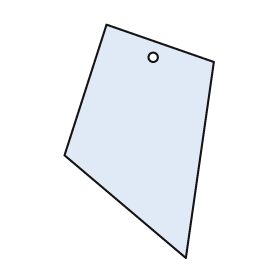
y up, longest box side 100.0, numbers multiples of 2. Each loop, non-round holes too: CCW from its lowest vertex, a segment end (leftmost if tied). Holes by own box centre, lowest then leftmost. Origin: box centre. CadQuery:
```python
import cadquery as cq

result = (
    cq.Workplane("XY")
    .moveTo(20.0, -50.0)
    .lineTo(32.0, 34.0)
    .lineTo(-14.0, 50.0)
    .lineTo(-32.0, -6.0)
    .close()
    .moveTo(6.0, 36.0)
    .circle(2.0)
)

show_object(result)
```